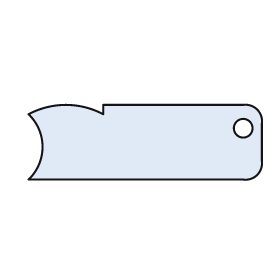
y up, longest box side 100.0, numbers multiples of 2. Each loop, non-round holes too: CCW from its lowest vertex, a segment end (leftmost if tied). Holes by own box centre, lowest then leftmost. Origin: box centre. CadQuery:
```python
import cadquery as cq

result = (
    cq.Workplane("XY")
    .moveTo(-50.0, -16.0)
    .lineTo(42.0, -16.0)
    .threePointArc((48.0, -14.0), (50.0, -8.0))
    .lineTo(50.0, 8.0)
    .threePointArc((48.0, 14.0), (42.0, 16.0))
    .lineTo(-18.0, 16.0)
    .lineTo(-18.0, 12.0)
    .threePointArc((-34.0, 16.0), (-50.0, 12.0))
    .threePointArc((-44.0, -2.0), (-50.0, -16.0))
    .close()
    .moveTo(42.0, 6.0)
    .circle(4.0)
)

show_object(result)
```